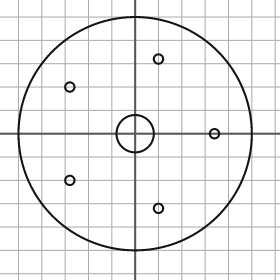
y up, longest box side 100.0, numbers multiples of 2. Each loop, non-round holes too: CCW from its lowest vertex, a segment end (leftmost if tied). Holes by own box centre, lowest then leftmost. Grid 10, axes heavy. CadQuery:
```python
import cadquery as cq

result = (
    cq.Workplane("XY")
    .moveTo(0.0, 0.0)
    .circle(50.0)
    .moveTo(10.0, -32.0)
    .circle(2.0)
    .moveTo(-28.0, -20.0)
    .circle(2.0)
    .moveTo(0.0, 0.0)
    .circle(8.0)
    .moveTo(34.0, 0.0)
    .circle(2.0)
    .moveTo(-28.0, 20.0)
    .circle(2.0)
    .moveTo(10.0, 32.0)
    .circle(2.0)
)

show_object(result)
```